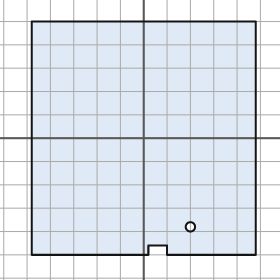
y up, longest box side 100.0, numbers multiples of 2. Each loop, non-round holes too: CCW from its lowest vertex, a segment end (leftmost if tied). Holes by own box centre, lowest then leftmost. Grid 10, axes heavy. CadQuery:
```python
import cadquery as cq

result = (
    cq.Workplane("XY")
    .moveTo(-48.0, -50.0)
    .lineTo(2.0, -50.0)
    .lineTo(2.0, -46.0)
    .lineTo(10.0, -46.0)
    .lineTo(10.0, -50.0)
    .lineTo(48.0, -50.0)
    .lineTo(48.0, 50.0)
    .lineTo(-48.0, 50.0)
    .close()
    .moveTo(20.0, -38.0)
    .circle(2.0)
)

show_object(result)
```